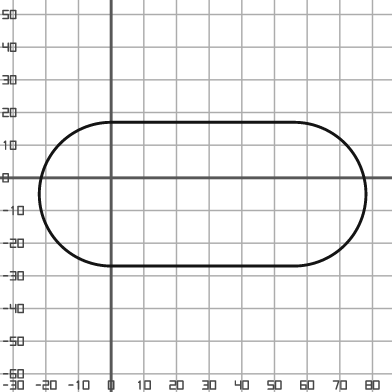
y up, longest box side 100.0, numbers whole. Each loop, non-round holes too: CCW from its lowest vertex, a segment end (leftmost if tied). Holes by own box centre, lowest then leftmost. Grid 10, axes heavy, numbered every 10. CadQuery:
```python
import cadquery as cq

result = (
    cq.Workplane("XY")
    .moveTo(0.0, -27.0)
    .lineTo(56.0, -27.0)
    .threePointArc((78.0, -5.0), (56.0, 17.0))
    .lineTo(0.0, 17.0)
    .threePointArc((-22.0, -5.0), (0.0, -27.0))
    .close()
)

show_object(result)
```